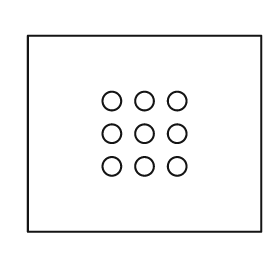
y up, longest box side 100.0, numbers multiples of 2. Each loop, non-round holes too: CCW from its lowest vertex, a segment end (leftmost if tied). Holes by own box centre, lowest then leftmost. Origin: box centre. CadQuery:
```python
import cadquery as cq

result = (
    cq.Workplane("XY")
    .moveTo(-50.0, -42.0)
    .lineTo(50.0, -42.0)
    .lineTo(50.0, 42.0)
    .lineTo(-50.0, 42.0)
    .close()
    .moveTo(-14.0, -14.0)
    .circle(4.0)
    .moveTo(0.0, -14.0)
    .circle(4.0)
    .moveTo(14.0, -14.0)
    .circle(4.0)
    .moveTo(-14.0, 0.0)
    .circle(4.0)
    .moveTo(0.0, 0.0)
    .circle(4.0)
    .moveTo(14.0, 0.0)
    .circle(4.0)
    .moveTo(-14.0, 14.0)
    .circle(4.0)
    .moveTo(0.0, 14.0)
    .circle(4.0)
    .moveTo(14.0, 14.0)
    .circle(4.0)
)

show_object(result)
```